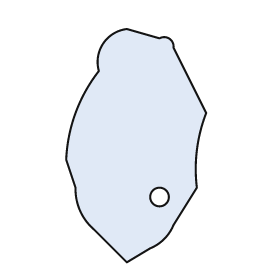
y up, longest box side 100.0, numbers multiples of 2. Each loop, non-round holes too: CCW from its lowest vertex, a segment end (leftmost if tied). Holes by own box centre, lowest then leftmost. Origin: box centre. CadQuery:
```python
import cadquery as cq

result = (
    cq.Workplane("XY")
    .moveTo(-4.0, -50.0)
    .lineTo(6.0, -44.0)
    .threePointArc((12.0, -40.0), (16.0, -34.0))
    .lineTo(26.0, -18.0)
    .threePointArc((26.0, -2.0), (30.0, 14.0))
    .lineTo(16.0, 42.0)
    .threePointArc((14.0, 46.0), (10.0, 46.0))
    .lineTo(-4.0, 50.0)
    .threePointArc((-14.0, 44.0), (-16.0, 32.0))
    .threePointArc((-26.0, 14.0), (-30.0, -6.0))
    .lineTo(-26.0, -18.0)
    .threePointArc((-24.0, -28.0), (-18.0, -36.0))
    .close()
    .moveTo(10.0, -22.0)
    .circle(4.0)
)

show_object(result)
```